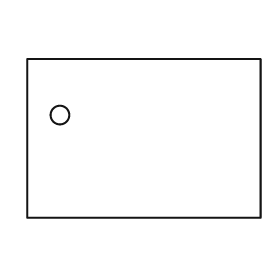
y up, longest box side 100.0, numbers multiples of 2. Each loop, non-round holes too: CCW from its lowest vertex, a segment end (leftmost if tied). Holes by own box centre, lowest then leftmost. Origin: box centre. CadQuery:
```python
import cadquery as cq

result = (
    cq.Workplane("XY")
    .moveTo(-50.0, -34.0)
    .lineTo(50.0, -34.0)
    .lineTo(50.0, 34.0)
    .lineTo(-50.0, 34.0)
    .close()
    .moveTo(-36.0, 10.0)
    .circle(4.0)
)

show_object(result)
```